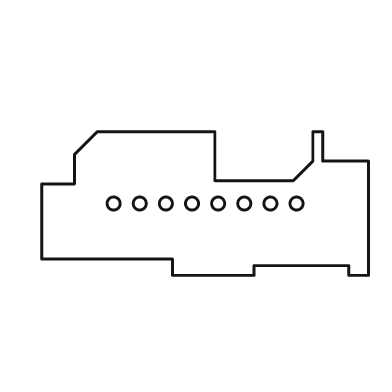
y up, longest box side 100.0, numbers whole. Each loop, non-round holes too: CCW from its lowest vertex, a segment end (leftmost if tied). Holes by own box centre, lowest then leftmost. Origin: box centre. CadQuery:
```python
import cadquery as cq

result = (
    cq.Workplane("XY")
    .moveTo(-10.0, -22.0)
    .lineTo(15.0, -22.0)
    .lineTo(15.0, -19.0)
    .lineTo(44.0, -19.0)
    .lineTo(44.0, -22.0)
    .lineTo(50.0, -22.0)
    .lineTo(50.0, 13.0)
    .lineTo(36.0, 13.0)
    .lineTo(36.0, 22.0)
    .lineTo(33.0, 22.0)
    .lineTo(33.0, 13.0)
    .lineTo(27.0, 7.0)
    .lineTo(3.0, 7.0)
    .lineTo(3.0, 22.0)
    .lineTo(-33.0, 22.0)
    .lineTo(-40.0, 15.0)
    .lineTo(-40.0, 6.0)
    .lineTo(-50.0, 6.0)
    .lineTo(-50.0, -17.0)
    .lineTo(-10.0, -17.0)
    .close()
    .moveTo(-28.0, 0.0)
    .circle(2.0)
    .moveTo(-20.0, 0.0)
    .circle(2.0)
    .moveTo(-12.0, 0.0)
    .circle(2.0)
    .moveTo(-4.0, 0.0)
    .circle(2.0)
    .moveTo(4.0, 0.0)
    .circle(2.0)
    .moveTo(12.0, 0.0)
    .circle(2.0)
    .moveTo(20.0, 0.0)
    .circle(2.0)
    .moveTo(28.0, 0.0)
    .circle(2.0)
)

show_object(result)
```